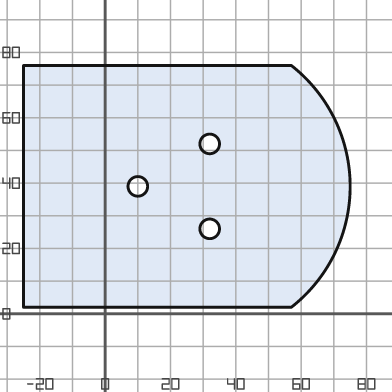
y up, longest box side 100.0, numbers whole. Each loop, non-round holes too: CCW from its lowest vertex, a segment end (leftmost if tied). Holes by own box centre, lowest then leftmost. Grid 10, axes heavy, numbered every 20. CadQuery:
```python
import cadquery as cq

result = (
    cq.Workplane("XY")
    .moveTo(-25.0, 2.0)
    .lineTo(57.0, 2.0)
    .threePointArc((75.0, 39.0), (57.0, 76.0))
    .lineTo(-25.0, 76.0)
    .close()
    .moveTo(32.0, 26.0)
    .circle(3.0)
    .moveTo(10.0, 39.0)
    .circle(3.0)
    .moveTo(32.0, 52.0)
    .circle(3.0)
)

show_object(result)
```